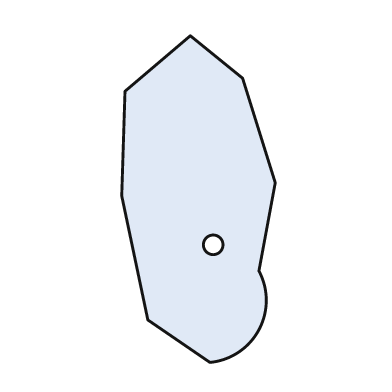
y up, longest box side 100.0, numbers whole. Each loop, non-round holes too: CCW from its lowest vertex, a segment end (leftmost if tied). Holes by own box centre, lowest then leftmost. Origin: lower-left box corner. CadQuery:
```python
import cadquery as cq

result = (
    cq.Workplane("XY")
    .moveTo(27.0, 0.0)
    .threePointArc((42.0, 10.0), (42.0, 28.0))
    .lineTo(47.0, 55.0)
    .lineTo(37.0, 87.0)
    .lineTo(21.0, 100.0)
    .lineTo(1.0, 83.0)
    .lineTo(0.0, 51.0)
    .lineTo(8.0, 13.0)
    .close()
    .moveTo(28.0, 36.0)
    .circle(3.0)
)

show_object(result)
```